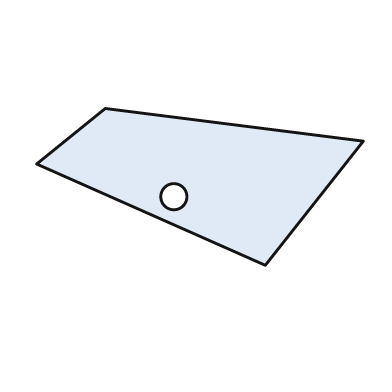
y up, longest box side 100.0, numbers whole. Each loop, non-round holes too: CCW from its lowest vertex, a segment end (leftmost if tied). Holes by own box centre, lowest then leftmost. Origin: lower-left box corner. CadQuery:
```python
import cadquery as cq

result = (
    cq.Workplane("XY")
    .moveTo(70.0, 0.0)
    .lineTo(100.0, 38.0)
    .lineTo(21.0, 48.0)
    .lineTo(0.0, 31.0)
    .close()
    .moveTo(42.0, 21.0)
    .circle(4.0)
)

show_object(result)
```